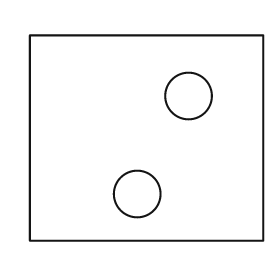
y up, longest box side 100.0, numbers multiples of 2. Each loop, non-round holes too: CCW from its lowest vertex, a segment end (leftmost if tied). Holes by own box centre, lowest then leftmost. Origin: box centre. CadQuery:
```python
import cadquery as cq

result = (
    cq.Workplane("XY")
    .moveTo(-50.0, -44.0)
    .lineTo(50.0, -44.0)
    .lineTo(50.0, 44.0)
    .lineTo(-50.0, 44.0)
    .close()
    .moveTo(-4.0, -24.0)
    .circle(10.0)
    .moveTo(18.0, 18.0)
    .circle(10.0)
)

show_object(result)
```